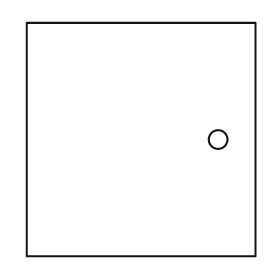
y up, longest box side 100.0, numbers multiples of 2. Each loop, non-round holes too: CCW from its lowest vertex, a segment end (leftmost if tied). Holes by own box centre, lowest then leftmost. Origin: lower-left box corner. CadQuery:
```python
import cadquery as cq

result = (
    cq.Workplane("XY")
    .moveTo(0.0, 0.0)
    .lineTo(98.0, 0.0)
    .lineTo(98.0, 100.0)
    .lineTo(0.0, 100.0)
    .close()
    .moveTo(82.0, 50.0)
    .circle(4.0)
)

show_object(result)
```